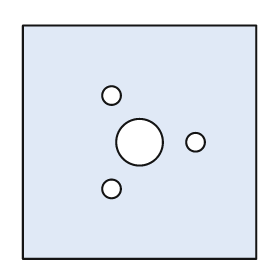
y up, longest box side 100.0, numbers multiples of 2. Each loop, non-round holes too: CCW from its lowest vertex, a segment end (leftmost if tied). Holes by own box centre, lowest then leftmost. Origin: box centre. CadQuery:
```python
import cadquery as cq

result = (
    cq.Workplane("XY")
    .moveTo(-50.0, -50.0)
    .lineTo(50.0, -50.0)
    .lineTo(50.0, 50.0)
    .lineTo(-50.0, 50.0)
    .close()
    .moveTo(-12.0, -20.0)
    .circle(4.0)
    .moveTo(0.0, 0.0)
    .circle(10.0)
    .moveTo(24.0, 0.0)
    .circle(4.0)
    .moveTo(-12.0, 20.0)
    .circle(4.0)
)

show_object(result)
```